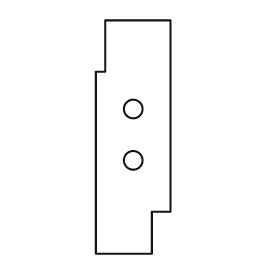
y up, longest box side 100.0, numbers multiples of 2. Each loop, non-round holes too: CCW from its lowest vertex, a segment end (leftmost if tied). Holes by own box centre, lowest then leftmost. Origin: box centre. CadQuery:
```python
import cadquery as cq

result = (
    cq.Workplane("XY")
    .moveTo(-16.0, -50.0)
    .lineTo(8.0, -50.0)
    .lineTo(8.0, -32.0)
    .lineTo(16.0, -32.0)
    .lineTo(16.0, 50.0)
    .lineTo(-12.0, 50.0)
    .lineTo(-12.0, 28.0)
    .lineTo(-16.0, 28.0)
    .close()
    .moveTo(0.0, -10.0)
    .circle(4.0)
    .moveTo(0.0, 12.0)
    .circle(4.0)
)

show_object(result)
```